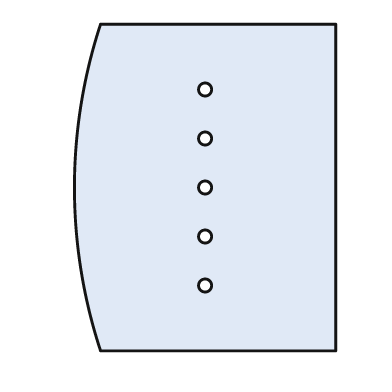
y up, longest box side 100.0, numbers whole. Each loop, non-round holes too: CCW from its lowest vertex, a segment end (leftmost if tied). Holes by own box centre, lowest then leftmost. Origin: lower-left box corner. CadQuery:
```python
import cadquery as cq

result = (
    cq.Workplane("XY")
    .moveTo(8.0, 0.0)
    .lineTo(80.0, 0.0)
    .lineTo(80.0, 100.0)
    .lineTo(8.0, 100.0)
    .threePointArc((0.0, 50.0), (8.0, 0.0))
    .close()
    .moveTo(40.0, 20.0)
    .circle(2.0)
    .moveTo(40.0, 35.0)
    .circle(2.0)
    .moveTo(40.0, 50.0)
    .circle(2.0)
    .moveTo(40.0, 65.0)
    .circle(2.0)
    .moveTo(40.0, 80.0)
    .circle(2.0)
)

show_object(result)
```